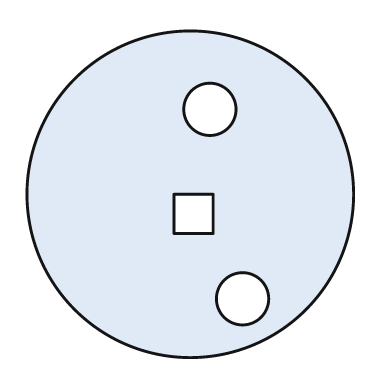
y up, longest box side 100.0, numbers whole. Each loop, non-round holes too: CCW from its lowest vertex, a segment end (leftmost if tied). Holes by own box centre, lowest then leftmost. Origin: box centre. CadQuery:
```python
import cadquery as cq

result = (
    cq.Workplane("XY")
    .moveTo(0.0, 0.0)
    .circle(50.0)
    .moveTo(16.0, -32.0)
    .circle(8.0)
    .moveTo(-5.0, -12.0)
    .lineTo(7.0, -12.0)
    .lineTo(7.0, 0.0)
    .lineTo(-5.0, 0.0)
    .close()
    .moveTo(6.0, 26.0)
    .circle(8.0)
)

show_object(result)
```